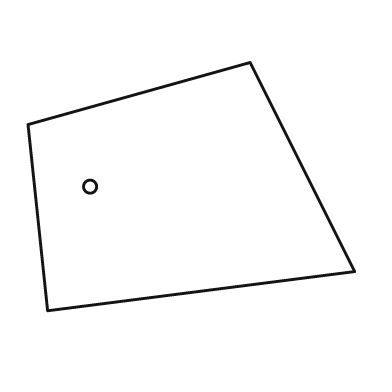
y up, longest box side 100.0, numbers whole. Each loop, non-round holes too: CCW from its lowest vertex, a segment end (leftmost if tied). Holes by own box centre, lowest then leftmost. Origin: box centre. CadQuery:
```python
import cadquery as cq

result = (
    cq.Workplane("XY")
    .moveTo(-44.0, -38.0)
    .lineTo(50.0, -26.0)
    .lineTo(18.0, 38.0)
    .lineTo(-50.0, 19.0)
    .close()
    .moveTo(-31.0, 0.0)
    .circle(2.0)
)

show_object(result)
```